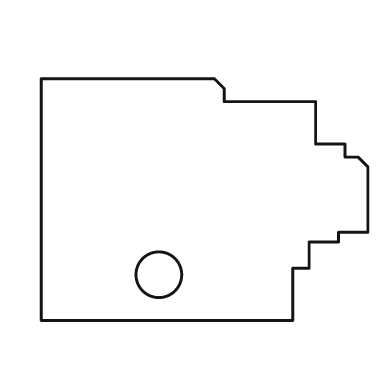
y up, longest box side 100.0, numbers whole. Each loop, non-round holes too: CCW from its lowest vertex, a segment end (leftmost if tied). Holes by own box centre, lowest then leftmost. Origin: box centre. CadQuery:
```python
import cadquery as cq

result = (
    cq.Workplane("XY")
    .moveTo(-50.0, -37.0)
    .lineTo(27.0, -37.0)
    .lineTo(27.0, -21.0)
    .lineTo(32.0, -21.0)
    .lineTo(32.0, -13.0)
    .lineTo(41.0, -13.0)
    .lineTo(41.0, -10.0)
    .lineTo(50.0, -10.0)
    .lineTo(50.0, 10.0)
    .lineTo(47.0, 13.0)
    .lineTo(43.0, 13.0)
    .lineTo(43.0, 17.0)
    .lineTo(34.0, 17.0)
    .lineTo(34.0, 30.0)
    .lineTo(6.0, 30.0)
    .lineTo(6.0, 34.0)
    .lineTo(3.0, 37.0)
    .lineTo(-50.0, 37.0)
    .close()
    .moveTo(-14.0, -23.0)
    .circle(7.0)
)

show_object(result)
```